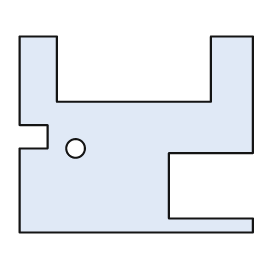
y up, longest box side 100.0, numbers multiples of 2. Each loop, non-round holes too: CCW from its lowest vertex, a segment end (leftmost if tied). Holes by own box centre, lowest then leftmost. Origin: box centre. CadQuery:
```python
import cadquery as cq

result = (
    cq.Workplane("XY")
    .moveTo(-50.0, -42.0)
    .lineTo(50.0, -42.0)
    .lineTo(50.0, -36.0)
    .lineTo(14.0, -36.0)
    .lineTo(14.0, -8.0)
    .lineTo(50.0, -8.0)
    .lineTo(50.0, 42.0)
    .lineTo(32.0, 42.0)
    .lineTo(32.0, 14.0)
    .lineTo(-34.0, 14.0)
    .lineTo(-34.0, 42.0)
    .lineTo(-50.0, 42.0)
    .lineTo(-50.0, 4.0)
    .lineTo(-38.0, 4.0)
    .lineTo(-38.0, -6.0)
    .lineTo(-50.0, -6.0)
    .close()
    .moveTo(-26.0, -6.0)
    .circle(4.0)
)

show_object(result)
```